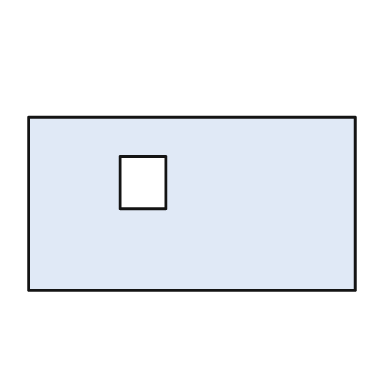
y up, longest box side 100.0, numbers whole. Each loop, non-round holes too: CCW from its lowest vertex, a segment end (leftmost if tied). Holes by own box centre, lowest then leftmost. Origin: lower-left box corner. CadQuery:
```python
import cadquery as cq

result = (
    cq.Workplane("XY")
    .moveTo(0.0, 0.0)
    .lineTo(100.0, 0.0)
    .lineTo(100.0, 53.0)
    .lineTo(0.0, 53.0)
    .close()
    .moveTo(28.0, 25.0)
    .lineTo(42.0, 25.0)
    .lineTo(42.0, 41.0)
    .lineTo(28.0, 41.0)
    .close()
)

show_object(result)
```